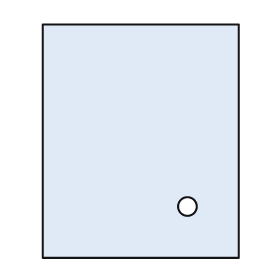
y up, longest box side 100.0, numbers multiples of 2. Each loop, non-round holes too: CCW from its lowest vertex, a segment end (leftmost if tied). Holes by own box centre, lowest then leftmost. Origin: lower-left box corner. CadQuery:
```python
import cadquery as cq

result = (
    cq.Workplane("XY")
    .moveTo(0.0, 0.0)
    .lineTo(84.0, 0.0)
    .lineTo(84.0, 100.0)
    .lineTo(0.0, 100.0)
    .close()
    .moveTo(62.0, 22.0)
    .circle(4.0)
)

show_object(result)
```